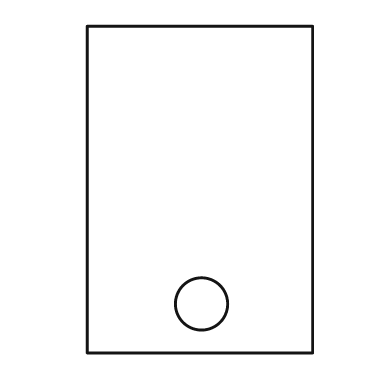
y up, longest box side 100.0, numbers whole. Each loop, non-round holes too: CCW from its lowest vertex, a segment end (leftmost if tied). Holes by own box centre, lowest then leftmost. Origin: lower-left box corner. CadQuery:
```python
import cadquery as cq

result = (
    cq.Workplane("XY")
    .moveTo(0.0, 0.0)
    .lineTo(69.0, 0.0)
    .lineTo(69.0, 100.0)
    .lineTo(0.0, 100.0)
    .close()
    .moveTo(35.0, 15.0)
    .circle(8.0)
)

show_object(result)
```